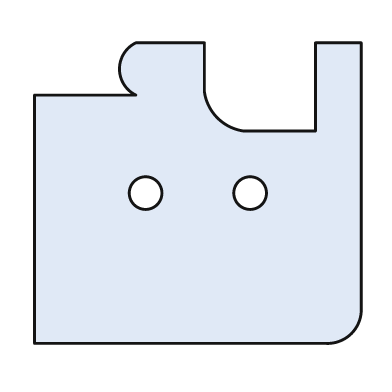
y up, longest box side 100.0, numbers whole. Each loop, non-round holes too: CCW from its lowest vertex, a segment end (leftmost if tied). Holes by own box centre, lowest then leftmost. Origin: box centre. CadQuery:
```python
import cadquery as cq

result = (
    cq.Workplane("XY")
    .moveTo(-50.0, -46.0)
    .lineTo(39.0, -46.0)
    .threePointArc((47.0, -43.0), (50.0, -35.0))
    .lineTo(50.0, 46.0)
    .lineTo(36.0, 46.0)
    .lineTo(36.0, 19.0)
    .lineTo(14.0, 19.0)
    .threePointArc((6.0, 23.0), (2.0, 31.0))
    .lineTo(2.0, 46.0)
    .lineTo(-19.0, 46.0)
    .threePointArc((-24.0, 38.0), (-19.0, 30.0))
    .lineTo(-50.0, 30.0)
    .close()
    .moveTo(-16.0, 0.0)
    .circle(5.0)
    .moveTo(16.0, 0.0)
    .circle(5.0)
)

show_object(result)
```